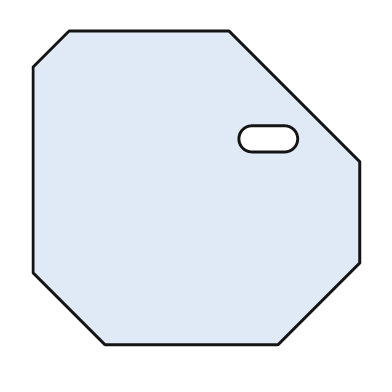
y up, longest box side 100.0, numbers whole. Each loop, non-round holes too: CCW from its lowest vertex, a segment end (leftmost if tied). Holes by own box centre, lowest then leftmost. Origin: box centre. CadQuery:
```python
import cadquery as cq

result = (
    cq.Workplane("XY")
    .moveTo(-28.0, -48.0)
    .lineTo(25.0, -48.0)
    .lineTo(50.0, -23.0)
    .lineTo(50.0, 8.0)
    .lineTo(10.0, 48.0)
    .lineTo(-39.0, 48.0)
    .lineTo(-50.0, 37.0)
    .lineTo(-50.0, -26.0)
    .close()
    .moveTo(17.0, 11.0)
    .lineTo(27.0, 11.0)
    .threePointArc((31.0, 15.0), (27.0, 19.0))
    .lineTo(17.0, 19.0)
    .threePointArc((13.0, 15.0), (17.0, 11.0))
    .close()
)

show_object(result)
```